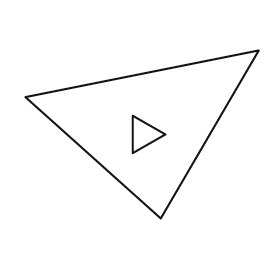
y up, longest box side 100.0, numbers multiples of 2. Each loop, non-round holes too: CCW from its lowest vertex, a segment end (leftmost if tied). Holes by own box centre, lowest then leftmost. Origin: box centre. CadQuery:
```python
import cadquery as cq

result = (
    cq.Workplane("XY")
    .moveTo(8.0, -36.0)
    .lineTo(50.0, 36.0)
    .lineTo(-50.0, 16.0)
    .close()
    .moveTo(-4.0, -8.0)
    .lineTo(10.0, 0.0)
    .lineTo(-4.0, 8.0)
    .close()
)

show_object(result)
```